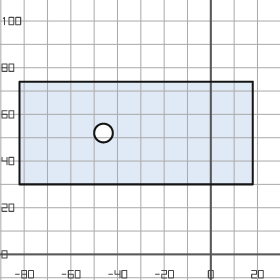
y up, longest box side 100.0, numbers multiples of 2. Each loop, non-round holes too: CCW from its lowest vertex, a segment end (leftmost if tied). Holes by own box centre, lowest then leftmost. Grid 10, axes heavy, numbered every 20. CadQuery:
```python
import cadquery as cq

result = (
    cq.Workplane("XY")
    .moveTo(-82.0, 30.0)
    .lineTo(18.0, 30.0)
    .lineTo(18.0, 74.0)
    .lineTo(-82.0, 74.0)
    .close()
    .moveTo(-46.0, 52.0)
    .circle(4.0)
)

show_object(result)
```